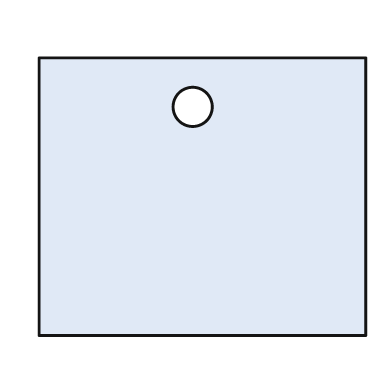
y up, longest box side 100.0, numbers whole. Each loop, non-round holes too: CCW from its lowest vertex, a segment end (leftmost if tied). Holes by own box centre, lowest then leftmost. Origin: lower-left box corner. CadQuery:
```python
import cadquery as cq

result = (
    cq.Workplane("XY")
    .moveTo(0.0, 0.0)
    .lineTo(100.0, 0.0)
    .lineTo(100.0, 85.0)
    .lineTo(0.0, 85.0)
    .close()
    .moveTo(47.0, 70.0)
    .circle(6.0)
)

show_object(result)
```